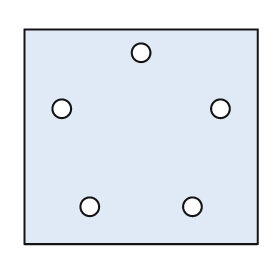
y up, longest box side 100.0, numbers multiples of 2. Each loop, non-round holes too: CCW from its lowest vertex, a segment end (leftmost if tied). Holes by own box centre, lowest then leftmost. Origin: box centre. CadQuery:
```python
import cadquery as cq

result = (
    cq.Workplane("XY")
    .moveTo(-50.0, -46.0)
    .lineTo(50.0, -46.0)
    .lineTo(50.0, 46.0)
    .lineTo(-50.0, 46.0)
    .close()
    .moveTo(-22.0, -30.0)
    .circle(4.0)
    .moveTo(22.0, -30.0)
    .circle(4.0)
    .moveTo(-34.0, 12.0)
    .circle(4.0)
    .moveTo(34.0, 12.0)
    .circle(4.0)
    .moveTo(0.0, 36.0)
    .circle(4.0)
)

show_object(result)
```